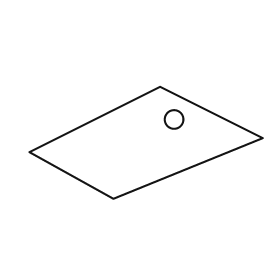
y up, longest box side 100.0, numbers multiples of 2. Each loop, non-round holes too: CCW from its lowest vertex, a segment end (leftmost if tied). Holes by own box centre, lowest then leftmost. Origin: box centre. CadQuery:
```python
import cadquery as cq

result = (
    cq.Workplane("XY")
    .moveTo(-14.0, -24.0)
    .lineTo(50.0, 2.0)
    .lineTo(6.0, 24.0)
    .lineTo(-50.0, -4.0)
    .close()
    .moveTo(12.0, 10.0)
    .circle(4.0)
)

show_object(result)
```